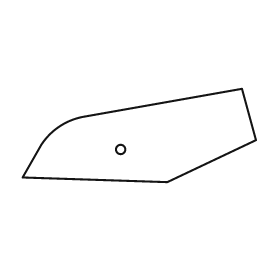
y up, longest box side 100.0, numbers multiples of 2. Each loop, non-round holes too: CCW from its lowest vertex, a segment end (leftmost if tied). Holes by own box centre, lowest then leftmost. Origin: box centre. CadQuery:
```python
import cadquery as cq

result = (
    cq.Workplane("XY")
    .moveTo(12.0, -20.0)
    .lineTo(50.0, -2.0)
    .lineTo(44.0, 20.0)
    .lineTo(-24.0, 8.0)
    .threePointArc((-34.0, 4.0), (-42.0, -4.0))
    .lineTo(-50.0, -18.0)
    .close()
    .moveTo(-8.0, -6.0)
    .circle(2.0)
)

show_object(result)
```